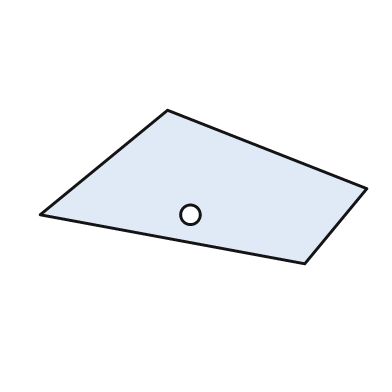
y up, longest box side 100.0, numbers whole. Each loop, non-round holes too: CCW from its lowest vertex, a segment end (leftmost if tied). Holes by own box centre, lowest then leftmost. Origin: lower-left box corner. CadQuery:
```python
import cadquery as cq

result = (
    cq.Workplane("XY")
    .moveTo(81.0, 0.0)
    .lineTo(100.0, 23.0)
    .lineTo(39.0, 47.0)
    .lineTo(0.0, 15.0)
    .close()
    .moveTo(46.0, 15.0)
    .circle(3.0)
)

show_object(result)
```